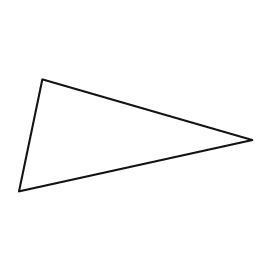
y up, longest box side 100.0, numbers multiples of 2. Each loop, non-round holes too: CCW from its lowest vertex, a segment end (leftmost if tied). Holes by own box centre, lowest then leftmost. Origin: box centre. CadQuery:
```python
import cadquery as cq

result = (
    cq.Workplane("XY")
    .moveTo(-50.0, -24.0)
    .lineTo(50.0, -2.0)
    .lineTo(-40.0, 24.0)
    .close()
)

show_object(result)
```